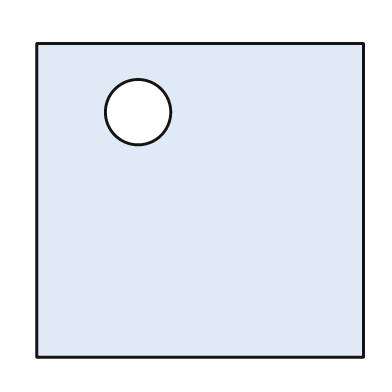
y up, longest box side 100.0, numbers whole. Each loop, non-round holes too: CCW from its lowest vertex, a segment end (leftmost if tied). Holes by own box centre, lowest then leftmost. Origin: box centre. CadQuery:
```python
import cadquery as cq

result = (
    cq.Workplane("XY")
    .moveTo(-50.0, -48.0)
    .lineTo(50.0, -48.0)
    .lineTo(50.0, 48.0)
    .lineTo(-50.0, 48.0)
    .close()
    .moveTo(-19.0, 27.0)
    .circle(10.0)
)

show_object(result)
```